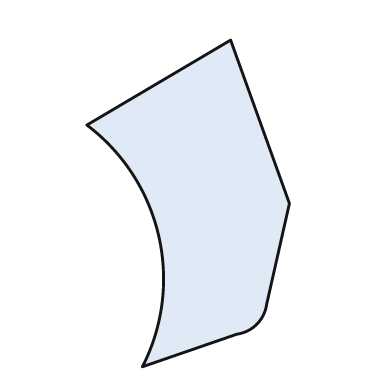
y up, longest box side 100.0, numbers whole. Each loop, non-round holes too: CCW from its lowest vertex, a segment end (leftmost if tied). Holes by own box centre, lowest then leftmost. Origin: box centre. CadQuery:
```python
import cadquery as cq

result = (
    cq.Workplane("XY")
    .moveTo(-14.0, -50.0)
    .lineTo(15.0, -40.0)
    .threePointArc((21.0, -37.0), (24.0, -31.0))
    .lineTo(31.0, 0.0)
    .lineTo(13.0, 50.0)
    .lineTo(-31.0, 24.0)
    .threePointArc((-9.0, -10.0), (-14.0, -50.0))
    .close()
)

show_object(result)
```